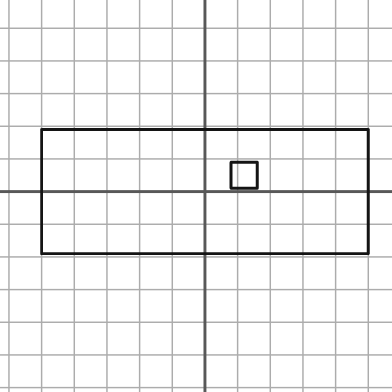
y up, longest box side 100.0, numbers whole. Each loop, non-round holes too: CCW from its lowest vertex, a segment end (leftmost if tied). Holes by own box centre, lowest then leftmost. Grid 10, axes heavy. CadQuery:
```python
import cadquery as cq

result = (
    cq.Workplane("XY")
    .moveTo(-50.0, -19.0)
    .lineTo(50.0, -19.0)
    .lineTo(50.0, 19.0)
    .lineTo(-50.0, 19.0)
    .close()
    .moveTo(8.0, 1.0)
    .lineTo(16.0, 1.0)
    .lineTo(16.0, 9.0)
    .lineTo(8.0, 9.0)
    .close()
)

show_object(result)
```